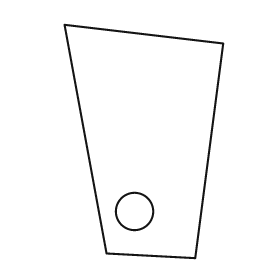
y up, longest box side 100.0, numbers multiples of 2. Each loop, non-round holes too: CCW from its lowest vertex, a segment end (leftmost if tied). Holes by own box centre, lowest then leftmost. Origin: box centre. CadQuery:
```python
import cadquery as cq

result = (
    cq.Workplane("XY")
    .moveTo(22.0, -50.0)
    .lineTo(34.0, 42.0)
    .lineTo(-34.0, 50.0)
    .lineTo(-16.0, -48.0)
    .close()
    .moveTo(-4.0, -30.0)
    .circle(8.0)
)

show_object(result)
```